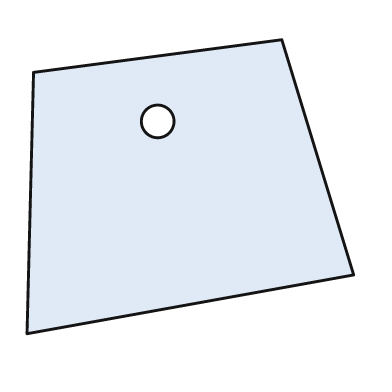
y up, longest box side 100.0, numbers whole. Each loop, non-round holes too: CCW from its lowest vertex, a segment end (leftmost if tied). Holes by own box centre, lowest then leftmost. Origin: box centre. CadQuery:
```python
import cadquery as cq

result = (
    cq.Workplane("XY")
    .moveTo(-50.0, -45.0)
    .lineTo(50.0, -27.0)
    .lineTo(28.0, 45.0)
    .lineTo(-48.0, 35.0)
    .close()
    .moveTo(-10.0, 20.0)
    .circle(5.0)
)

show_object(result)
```